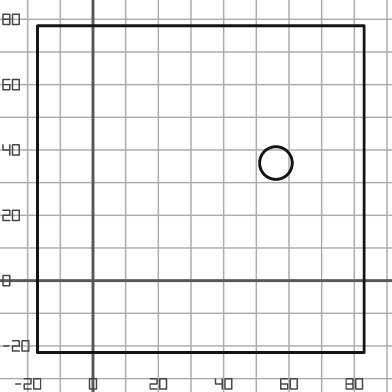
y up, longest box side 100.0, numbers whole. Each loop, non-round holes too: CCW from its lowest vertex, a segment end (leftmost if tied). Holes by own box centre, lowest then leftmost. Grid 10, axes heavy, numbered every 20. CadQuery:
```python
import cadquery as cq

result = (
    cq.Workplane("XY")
    .moveTo(-17.0, -22.0)
    .lineTo(83.0, -22.0)
    .lineTo(83.0, 78.0)
    .lineTo(-17.0, 78.0)
    .close()
    .moveTo(56.0, 36.0)
    .circle(5.0)
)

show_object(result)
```